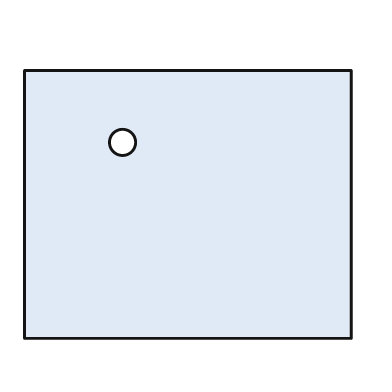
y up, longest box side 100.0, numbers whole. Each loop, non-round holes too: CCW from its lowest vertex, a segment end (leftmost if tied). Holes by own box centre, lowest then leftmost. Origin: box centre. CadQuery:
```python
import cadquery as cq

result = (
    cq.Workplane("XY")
    .moveTo(-50.0, -41.0)
    .lineTo(50.0, -41.0)
    .lineTo(50.0, 41.0)
    .lineTo(-50.0, 41.0)
    .close()
    .moveTo(-20.0, 19.0)
    .circle(4.0)
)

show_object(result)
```